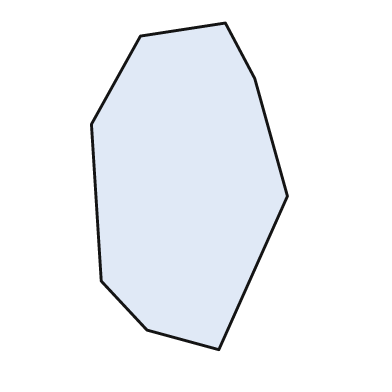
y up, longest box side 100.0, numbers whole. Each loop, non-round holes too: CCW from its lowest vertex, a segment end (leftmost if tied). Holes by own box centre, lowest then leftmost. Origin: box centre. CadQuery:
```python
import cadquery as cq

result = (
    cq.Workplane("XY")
    .moveTo(9.0, -50.0)
    .lineTo(30.0, -3.0)
    .lineTo(20.0, 33.0)
    .lineTo(11.0, 50.0)
    .lineTo(-15.0, 46.0)
    .lineTo(-30.0, 19.0)
    .lineTo(-27.0, -29.0)
    .lineTo(-13.0, -44.0)
    .close()
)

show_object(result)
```